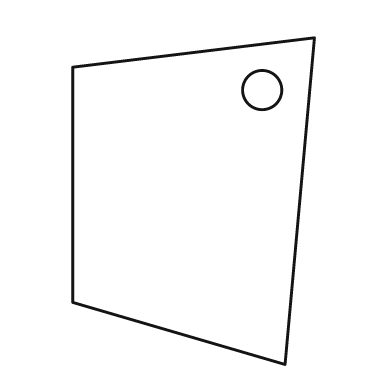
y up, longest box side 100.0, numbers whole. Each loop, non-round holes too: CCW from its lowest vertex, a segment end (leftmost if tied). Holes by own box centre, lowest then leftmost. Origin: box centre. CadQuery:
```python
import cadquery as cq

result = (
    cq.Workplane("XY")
    .moveTo(28.0, -50.0)
    .lineTo(37.0, 50.0)
    .lineTo(-37.0, 41.0)
    .lineTo(-37.0, -31.0)
    .close()
    .moveTo(21.0, 34.0)
    .circle(6.0)
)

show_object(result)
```